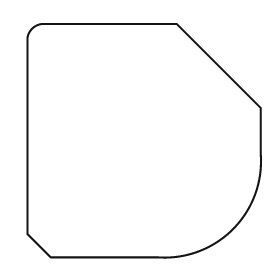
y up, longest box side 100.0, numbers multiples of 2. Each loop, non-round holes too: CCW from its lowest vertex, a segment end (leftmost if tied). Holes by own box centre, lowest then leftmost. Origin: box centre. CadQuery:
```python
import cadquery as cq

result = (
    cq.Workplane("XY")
    .moveTo(-40.0, -50.0)
    .lineTo(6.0, -50.0)
    .threePointArc((38.0, -38.0), (50.0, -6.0))
    .lineTo(50.0, 14.0)
    .lineTo(14.0, 50.0)
    .lineTo(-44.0, 50.0)
    .threePointArc((-48.0, 48.0), (-50.0, 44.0))
    .lineTo(-50.0, -40.0)
    .close()
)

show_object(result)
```